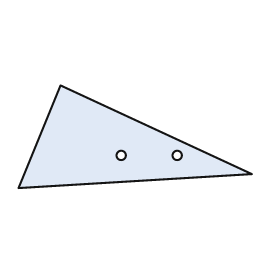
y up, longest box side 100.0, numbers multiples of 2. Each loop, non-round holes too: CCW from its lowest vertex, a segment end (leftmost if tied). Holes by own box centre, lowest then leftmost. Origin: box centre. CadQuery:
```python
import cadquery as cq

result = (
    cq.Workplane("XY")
    .moveTo(-50.0, -22.0)
    .lineTo(50.0, -16.0)
    .lineTo(-32.0, 22.0)
    .close()
    .moveTo(-6.0, -8.0)
    .circle(2.0)
    .moveTo(18.0, -8.0)
    .circle(2.0)
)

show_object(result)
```